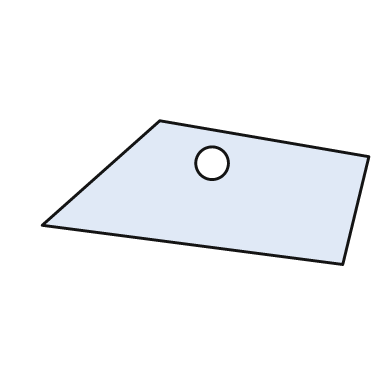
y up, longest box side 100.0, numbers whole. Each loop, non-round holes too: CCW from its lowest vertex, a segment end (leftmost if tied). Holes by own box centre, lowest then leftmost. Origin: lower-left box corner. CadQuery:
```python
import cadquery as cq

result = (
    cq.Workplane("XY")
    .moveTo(92.0, 0.0)
    .lineTo(100.0, 33.0)
    .lineTo(36.0, 44.0)
    .lineTo(0.0, 12.0)
    .close()
    .moveTo(52.0, 31.0)
    .circle(5.0)
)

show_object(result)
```